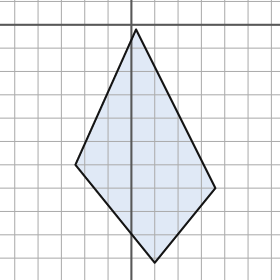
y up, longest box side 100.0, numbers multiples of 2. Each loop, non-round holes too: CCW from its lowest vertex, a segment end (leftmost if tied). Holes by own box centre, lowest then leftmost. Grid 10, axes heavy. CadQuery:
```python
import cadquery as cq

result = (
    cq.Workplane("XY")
    .moveTo(10.0, -102.0)
    .lineTo(36.0, -70.0)
    .lineTo(2.0, -2.0)
    .lineTo(-24.0, -60.0)
    .close()
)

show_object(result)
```